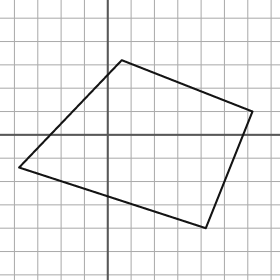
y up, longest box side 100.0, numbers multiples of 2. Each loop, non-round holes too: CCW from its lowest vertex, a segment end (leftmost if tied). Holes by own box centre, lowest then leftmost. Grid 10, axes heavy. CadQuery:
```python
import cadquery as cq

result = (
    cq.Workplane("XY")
    .moveTo(42.0, -40.0)
    .lineTo(62.0, 10.0)
    .lineTo(6.0, 32.0)
    .lineTo(-38.0, -14.0)
    .close()
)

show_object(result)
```